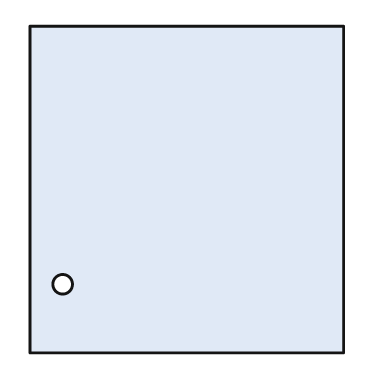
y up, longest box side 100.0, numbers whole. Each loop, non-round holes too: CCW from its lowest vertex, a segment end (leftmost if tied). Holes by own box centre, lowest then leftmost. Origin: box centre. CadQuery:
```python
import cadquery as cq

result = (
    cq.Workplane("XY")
    .moveTo(-48.0, -50.0)
    .lineTo(48.0, -50.0)
    .lineTo(48.0, 50.0)
    .lineTo(-48.0, 50.0)
    .close()
    .moveTo(-38.0, -29.0)
    .circle(3.0)
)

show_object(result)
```